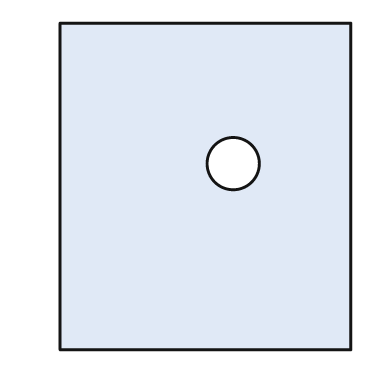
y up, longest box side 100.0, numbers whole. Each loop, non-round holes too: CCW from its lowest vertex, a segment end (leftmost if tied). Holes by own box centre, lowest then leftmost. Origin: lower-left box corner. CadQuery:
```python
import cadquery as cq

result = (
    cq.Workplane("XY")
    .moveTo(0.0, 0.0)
    .lineTo(89.0, 0.0)
    .lineTo(89.0, 100.0)
    .lineTo(0.0, 100.0)
    .close()
    .moveTo(53.0, 57.0)
    .circle(8.0)
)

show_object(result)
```